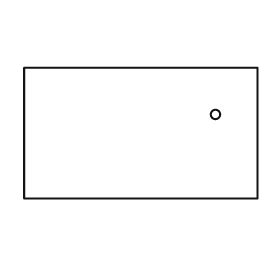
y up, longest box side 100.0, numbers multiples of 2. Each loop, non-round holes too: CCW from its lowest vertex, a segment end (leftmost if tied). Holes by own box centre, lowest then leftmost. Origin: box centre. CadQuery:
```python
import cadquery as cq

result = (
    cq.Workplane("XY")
    .moveTo(-50.0, -28.0)
    .lineTo(50.0, -28.0)
    .lineTo(50.0, 28.0)
    .lineTo(-50.0, 28.0)
    .close()
    .moveTo(32.0, 8.0)
    .circle(2.0)
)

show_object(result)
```